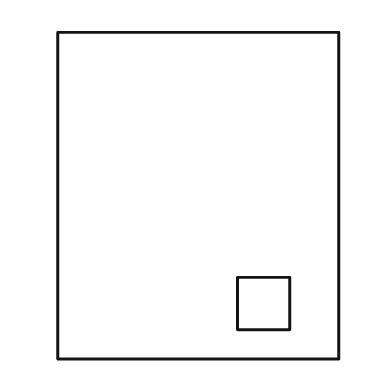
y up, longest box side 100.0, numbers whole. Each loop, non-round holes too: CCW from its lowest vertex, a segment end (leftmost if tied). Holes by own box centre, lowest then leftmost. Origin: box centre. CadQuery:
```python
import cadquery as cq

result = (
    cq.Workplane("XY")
    .moveTo(-43.0, -50.0)
    .lineTo(43.0, -50.0)
    .lineTo(43.0, 50.0)
    .lineTo(-43.0, 50.0)
    .close()
    .moveTo(12.0, -41.0)
    .lineTo(28.0, -41.0)
    .lineTo(28.0, -25.0)
    .lineTo(12.0, -25.0)
    .close()
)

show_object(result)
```